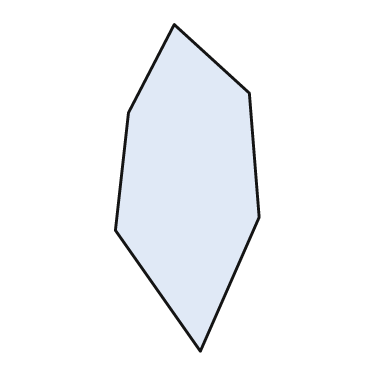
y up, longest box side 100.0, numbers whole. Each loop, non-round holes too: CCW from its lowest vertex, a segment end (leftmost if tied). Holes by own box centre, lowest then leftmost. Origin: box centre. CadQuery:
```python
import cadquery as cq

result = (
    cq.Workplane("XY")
    .moveTo(4.0, -50.0)
    .lineTo(22.0, -9.0)
    .lineTo(19.0, 29.0)
    .lineTo(-4.0, 50.0)
    .lineTo(-18.0, 23.0)
    .lineTo(-22.0, -13.0)
    .close()
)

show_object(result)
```